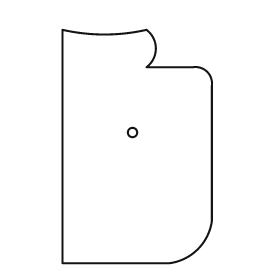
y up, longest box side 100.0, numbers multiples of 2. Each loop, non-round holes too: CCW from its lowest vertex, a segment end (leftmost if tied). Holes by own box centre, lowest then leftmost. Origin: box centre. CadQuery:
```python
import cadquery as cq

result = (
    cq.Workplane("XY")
    .moveTo(-32.0, -50.0)
    .lineTo(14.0, -50.0)
    .threePointArc((26.0, -44.0), (32.0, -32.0))
    .lineTo(32.0, 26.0)
    .threePointArc((30.0, 32.0), (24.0, 34.0))
    .lineTo(4.0, 34.0)
    .threePointArc((8.0, 42.0), (4.0, 50.0))
    .threePointArc((-14.0, 48.0), (-32.0, 50.0))
    .close()
    .moveTo(-2.0, 6.0)
    .circle(2.0)
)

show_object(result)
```